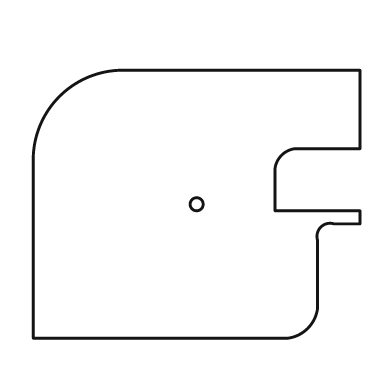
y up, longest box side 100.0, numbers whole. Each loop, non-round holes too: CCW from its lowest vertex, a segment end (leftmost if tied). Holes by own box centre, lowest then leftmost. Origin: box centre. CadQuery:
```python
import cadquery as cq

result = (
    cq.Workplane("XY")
    .moveTo(-50.0, -41.0)
    .lineTo(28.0, -41.0)
    .threePointArc((34.0, -38.0), (37.0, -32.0))
    .lineTo(37.0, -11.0)
    .threePointArc((38.0, -7.0), (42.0, -6.0))
    .lineTo(50.0, -6.0)
    .lineTo(50.0, -2.0)
    .lineTo(24.0, -2.0)
    .lineTo(24.0, 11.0)
    .threePointArc((26.0, 15.0), (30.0, 17.0))
    .lineTo(50.0, 17.0)
    .lineTo(50.0, 41.0)
    .lineTo(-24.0, 41.0)
    .threePointArc((-42.0, 33.0), (-50.0, 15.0))
    .close()
    .moveTo(0.0, 0.0)
    .circle(2.0)
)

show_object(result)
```